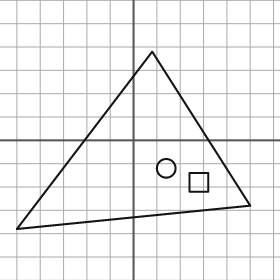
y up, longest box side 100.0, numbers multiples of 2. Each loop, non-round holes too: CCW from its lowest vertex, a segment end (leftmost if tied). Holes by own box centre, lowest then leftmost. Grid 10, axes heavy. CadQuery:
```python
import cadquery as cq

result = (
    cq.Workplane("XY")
    .moveTo(-50.0, -38.0)
    .lineTo(50.0, -28.0)
    .lineTo(8.0, 38.0)
    .close()
    .moveTo(24.0, -22.0)
    .lineTo(32.0, -22.0)
    .lineTo(32.0, -14.0)
    .lineTo(24.0, -14.0)
    .close()
    .moveTo(14.0, -12.0)
    .circle(4.0)
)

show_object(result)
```